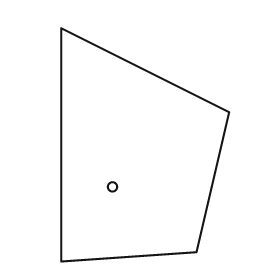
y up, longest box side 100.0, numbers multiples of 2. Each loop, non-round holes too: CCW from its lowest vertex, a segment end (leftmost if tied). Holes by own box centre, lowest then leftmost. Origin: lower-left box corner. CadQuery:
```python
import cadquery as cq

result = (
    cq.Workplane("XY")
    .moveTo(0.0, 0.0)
    .lineTo(58.0, 4.0)
    .lineTo(72.0, 64.0)
    .lineTo(0.0, 100.0)
    .close()
    .moveTo(22.0, 32.0)
    .circle(2.0)
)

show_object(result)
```